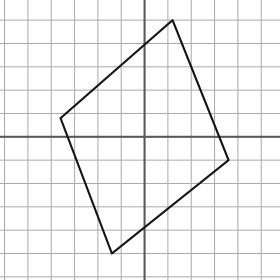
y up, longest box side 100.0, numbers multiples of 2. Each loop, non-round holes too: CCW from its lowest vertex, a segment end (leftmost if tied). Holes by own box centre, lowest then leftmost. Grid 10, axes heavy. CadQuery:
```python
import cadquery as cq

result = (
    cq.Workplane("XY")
    .moveTo(-14.0, -50.0)
    .lineTo(36.0, -10.0)
    .lineTo(12.0, 50.0)
    .lineTo(-36.0, 8.0)
    .close()
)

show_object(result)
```